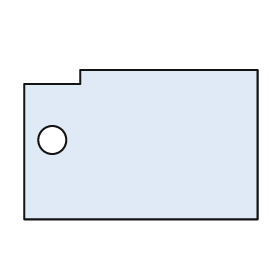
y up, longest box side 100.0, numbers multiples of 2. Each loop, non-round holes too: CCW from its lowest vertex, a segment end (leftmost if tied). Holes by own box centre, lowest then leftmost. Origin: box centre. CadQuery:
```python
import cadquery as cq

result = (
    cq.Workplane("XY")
    .moveTo(-50.0, -32.0)
    .lineTo(50.0, -32.0)
    .lineTo(50.0, 32.0)
    .lineTo(-26.0, 32.0)
    .lineTo(-26.0, 26.0)
    .lineTo(-50.0, 26.0)
    .close()
    .moveTo(-38.0, 2.0)
    .circle(6.0)
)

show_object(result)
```